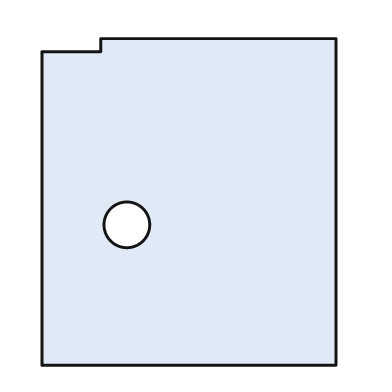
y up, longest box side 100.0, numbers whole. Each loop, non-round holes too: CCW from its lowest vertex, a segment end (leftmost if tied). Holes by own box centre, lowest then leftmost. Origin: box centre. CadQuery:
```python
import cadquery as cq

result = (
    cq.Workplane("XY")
    .moveTo(-45.0, -50.0)
    .lineTo(45.0, -50.0)
    .lineTo(45.0, 50.0)
    .lineTo(-27.0, 50.0)
    .lineTo(-27.0, 46.0)
    .lineTo(-45.0, 46.0)
    .close()
    .moveTo(-19.0, -7.0)
    .circle(7.0)
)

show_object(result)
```